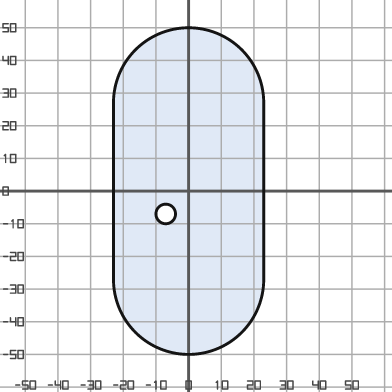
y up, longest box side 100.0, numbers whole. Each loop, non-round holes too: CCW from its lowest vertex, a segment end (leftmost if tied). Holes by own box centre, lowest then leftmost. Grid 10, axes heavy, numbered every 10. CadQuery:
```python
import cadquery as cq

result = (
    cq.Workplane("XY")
    .moveTo(-23.0, -27.0)
    .threePointArc((0.0, -50.0), (23.0, -27.0))
    .lineTo(23.0, 27.0)
    .threePointArc((0.0, 50.0), (-23.0, 27.0))
    .close()
    .moveTo(-7.0, -7.0)
    .circle(3.0)
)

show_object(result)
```